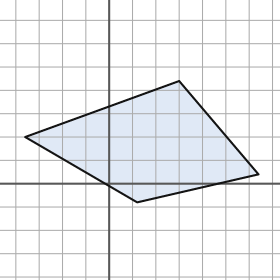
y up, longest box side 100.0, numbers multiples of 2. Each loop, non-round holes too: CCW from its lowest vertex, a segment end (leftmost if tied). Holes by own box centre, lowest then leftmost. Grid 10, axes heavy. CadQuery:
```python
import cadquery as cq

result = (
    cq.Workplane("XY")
    .moveTo(12.0, -8.0)
    .lineTo(64.0, 4.0)
    .lineTo(30.0, 44.0)
    .lineTo(-36.0, 20.0)
    .close()
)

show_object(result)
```